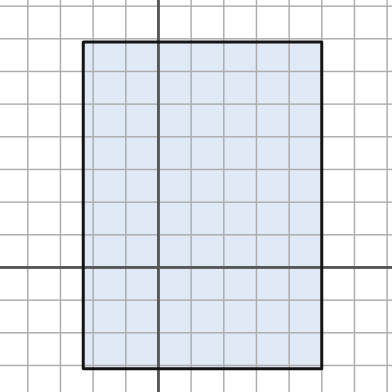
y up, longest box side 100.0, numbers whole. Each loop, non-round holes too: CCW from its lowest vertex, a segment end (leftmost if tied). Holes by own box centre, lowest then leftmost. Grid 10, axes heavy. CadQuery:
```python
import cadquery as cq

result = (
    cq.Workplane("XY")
    .moveTo(-23.0, -31.0)
    .lineTo(50.0, -31.0)
    .lineTo(50.0, 69.0)
    .lineTo(-23.0, 69.0)
    .close()
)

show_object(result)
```